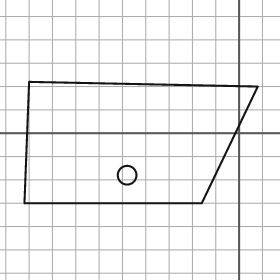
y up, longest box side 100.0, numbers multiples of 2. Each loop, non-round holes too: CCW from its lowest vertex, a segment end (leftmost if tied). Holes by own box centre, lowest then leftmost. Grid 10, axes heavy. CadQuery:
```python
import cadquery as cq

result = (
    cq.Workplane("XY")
    .moveTo(-92.0, -30.0)
    .lineTo(-16.0, -30.0)
    .lineTo(8.0, 20.0)
    .lineTo(-90.0, 22.0)
    .close()
    .moveTo(-48.0, -18.0)
    .circle(4.0)
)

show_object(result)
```